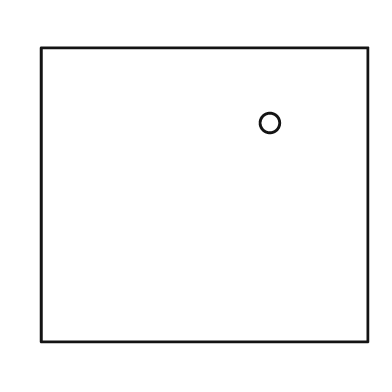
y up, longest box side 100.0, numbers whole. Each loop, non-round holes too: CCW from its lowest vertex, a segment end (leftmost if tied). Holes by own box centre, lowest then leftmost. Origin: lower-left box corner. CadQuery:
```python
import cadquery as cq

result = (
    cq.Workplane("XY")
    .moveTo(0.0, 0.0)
    .lineTo(100.0, 0.0)
    .lineTo(100.0, 90.0)
    .lineTo(0.0, 90.0)
    .close()
    .moveTo(70.0, 67.0)
    .circle(3.0)
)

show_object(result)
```